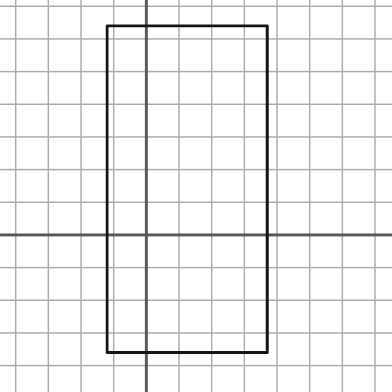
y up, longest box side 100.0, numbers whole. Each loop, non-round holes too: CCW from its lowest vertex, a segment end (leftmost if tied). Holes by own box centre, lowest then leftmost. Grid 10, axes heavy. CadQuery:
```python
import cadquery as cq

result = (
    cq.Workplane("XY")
    .moveTo(-12.0, -36.0)
    .lineTo(37.0, -36.0)
    .lineTo(37.0, 64.0)
    .lineTo(-12.0, 64.0)
    .close()
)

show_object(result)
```